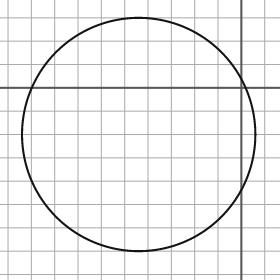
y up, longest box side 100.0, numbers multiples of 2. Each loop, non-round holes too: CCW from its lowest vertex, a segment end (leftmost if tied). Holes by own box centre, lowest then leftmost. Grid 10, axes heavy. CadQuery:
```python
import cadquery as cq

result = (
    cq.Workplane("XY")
    .moveTo(-44.0, -20.0)
    .circle(50.0)
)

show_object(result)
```